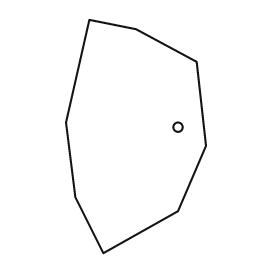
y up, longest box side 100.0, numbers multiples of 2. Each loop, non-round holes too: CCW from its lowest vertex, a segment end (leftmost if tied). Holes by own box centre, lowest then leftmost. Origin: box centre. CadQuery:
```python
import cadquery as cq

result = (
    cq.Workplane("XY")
    .moveTo(-14.0, -50.0)
    .lineTo(18.0, -32.0)
    .lineTo(30.0, -4.0)
    .lineTo(26.0, 32.0)
    .lineTo(0.0, 46.0)
    .lineTo(-20.0, 50.0)
    .lineTo(-30.0, 6.0)
    .lineTo(-26.0, -26.0)
    .close()
    .moveTo(18.0, 4.0)
    .circle(2.0)
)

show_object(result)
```